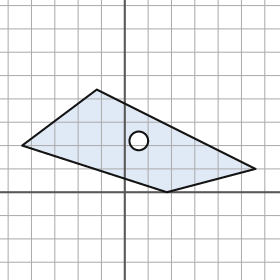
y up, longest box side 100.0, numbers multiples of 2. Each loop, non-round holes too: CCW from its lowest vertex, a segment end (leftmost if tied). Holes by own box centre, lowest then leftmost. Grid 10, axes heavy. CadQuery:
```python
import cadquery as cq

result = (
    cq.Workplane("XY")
    .moveTo(18.0, 0.0)
    .lineTo(56.0, 10.0)
    .lineTo(-12.0, 44.0)
    .lineTo(-44.0, 20.0)
    .close()
    .moveTo(6.0, 22.0)
    .circle(4.0)
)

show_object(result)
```